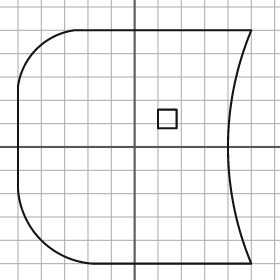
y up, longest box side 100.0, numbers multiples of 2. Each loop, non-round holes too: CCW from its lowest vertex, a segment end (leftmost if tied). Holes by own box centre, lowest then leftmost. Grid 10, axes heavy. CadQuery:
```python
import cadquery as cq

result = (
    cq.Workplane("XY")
    .moveTo(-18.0, -50.0)
    .lineTo(50.0, -50.0)
    .threePointArc((40.0, 0.0), (50.0, 50.0))
    .lineTo(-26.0, 50.0)
    .threePointArc((-42.0, 42.0), (-50.0, 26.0))
    .lineTo(-50.0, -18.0)
    .threePointArc((-40.0, -40.0), (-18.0, -50.0))
    .close()
    .moveTo(10.0, 8.0)
    .lineTo(18.0, 8.0)
    .lineTo(18.0, 16.0)
    .lineTo(10.0, 16.0)
    .close()
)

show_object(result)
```